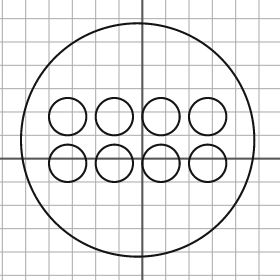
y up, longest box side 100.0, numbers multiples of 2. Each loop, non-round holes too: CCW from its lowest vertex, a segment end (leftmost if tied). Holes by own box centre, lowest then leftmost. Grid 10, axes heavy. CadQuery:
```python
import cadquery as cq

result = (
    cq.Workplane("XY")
    .moveTo(-2.0, 8.0)
    .circle(50.0)
    .moveTo(-32.0, -2.0)
    .circle(8.0)
    .moveTo(-12.0, -2.0)
    .circle(8.0)
    .moveTo(8.0, -2.0)
    .circle(8.0)
    .moveTo(28.0, -2.0)
    .circle(8.0)
    .moveTo(-32.0, 18.0)
    .circle(8.0)
    .moveTo(-12.0, 18.0)
    .circle(8.0)
    .moveTo(8.0, 18.0)
    .circle(8.0)
    .moveTo(28.0, 18.0)
    .circle(8.0)
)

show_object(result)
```